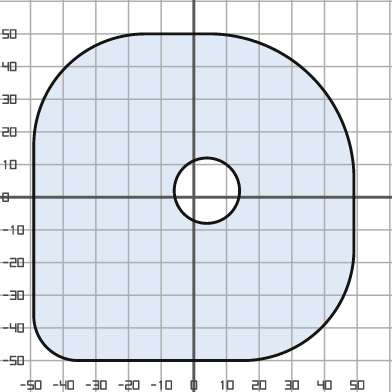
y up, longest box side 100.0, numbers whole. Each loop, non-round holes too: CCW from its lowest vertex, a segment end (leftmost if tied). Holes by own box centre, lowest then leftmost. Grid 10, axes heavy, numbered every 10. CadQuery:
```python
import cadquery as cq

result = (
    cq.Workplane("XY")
    .moveTo(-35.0, -50.0)
    .lineTo(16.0, -50.0)
    .threePointArc((39.0, -40.0), (49.0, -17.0))
    .lineTo(49.0, 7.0)
    .threePointArc((36.0, 37.0), (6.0, 50.0))
    .lineTo(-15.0, 50.0)
    .threePointArc((-39.0, 40.0), (-49.0, 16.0))
    .lineTo(-49.0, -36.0)
    .threePointArc((-45.0, -46.0), (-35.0, -50.0))
    .close()
    .moveTo(4.0, 2.0)
    .circle(10.0)
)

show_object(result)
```